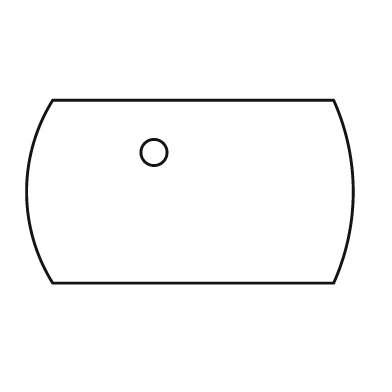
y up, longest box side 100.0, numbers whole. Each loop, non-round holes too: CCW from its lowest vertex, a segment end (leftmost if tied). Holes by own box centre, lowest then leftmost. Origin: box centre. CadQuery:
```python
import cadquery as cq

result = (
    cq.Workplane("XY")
    .moveTo(-42.0, -28.0)
    .lineTo(44.0, -28.0)
    .threePointArc((50.0, 0.0), (44.0, 28.0))
    .lineTo(-42.0, 28.0)
    .threePointArc((-50.0, 0.0), (-42.0, -28.0))
    .close()
    .moveTo(-11.0, 12.0)
    .circle(4.0)
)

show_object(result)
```